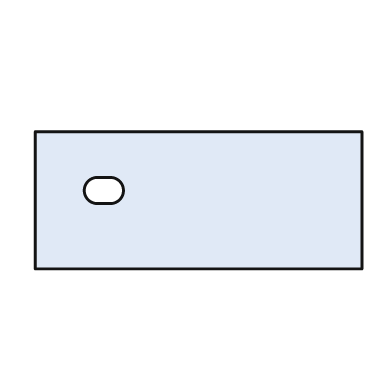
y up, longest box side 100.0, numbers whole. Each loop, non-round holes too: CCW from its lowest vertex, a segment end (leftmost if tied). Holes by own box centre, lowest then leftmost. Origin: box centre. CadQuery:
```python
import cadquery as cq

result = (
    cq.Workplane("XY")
    .moveTo(-50.0, -21.0)
    .lineTo(50.0, -21.0)
    .lineTo(50.0, 21.0)
    .lineTo(-50.0, 21.0)
    .close()
    .moveTo(-31.0, -1.0)
    .lineTo(-27.0, -1.0)
    .threePointArc((-23.0, 3.0), (-27.0, 7.0))
    .lineTo(-31.0, 7.0)
    .threePointArc((-35.0, 3.0), (-31.0, -1.0))
    .close()
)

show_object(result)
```